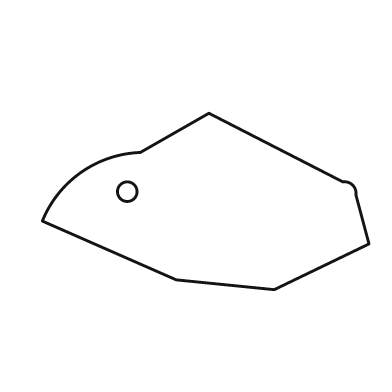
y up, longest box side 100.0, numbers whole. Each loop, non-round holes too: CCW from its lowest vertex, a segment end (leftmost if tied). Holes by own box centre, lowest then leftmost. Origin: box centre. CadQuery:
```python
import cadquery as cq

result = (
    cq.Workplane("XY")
    .moveTo(21.0, -27.0)
    .lineTo(50.0, -13.0)
    .lineTo(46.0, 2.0)
    .threePointArc((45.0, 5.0), (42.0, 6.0))
    .lineTo(1.0, 27.0)
    .lineTo(-20.0, 15.0)
    .threePointArc((-38.0, 9.0), (-50.0, -6.0))
    .lineTo(-9.0, -24.0)
    .close()
    .moveTo(-24.0, 3.0)
    .circle(3.0)
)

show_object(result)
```